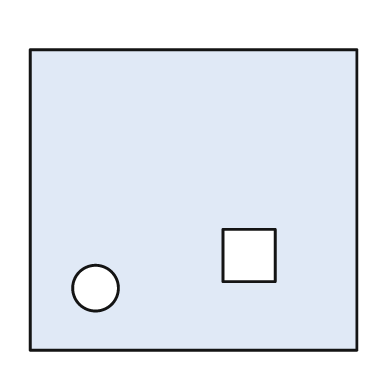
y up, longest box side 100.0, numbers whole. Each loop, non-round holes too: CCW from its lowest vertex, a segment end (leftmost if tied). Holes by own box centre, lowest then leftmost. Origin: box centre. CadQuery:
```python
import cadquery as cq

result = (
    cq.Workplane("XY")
    .moveTo(-50.0, -46.0)
    .lineTo(50.0, -46.0)
    .lineTo(50.0, 46.0)
    .lineTo(-50.0, 46.0)
    .close()
    .moveTo(-30.0, -27.0)
    .circle(7.0)
    .moveTo(9.0, -25.0)
    .lineTo(25.0, -25.0)
    .lineTo(25.0, -9.0)
    .lineTo(9.0, -9.0)
    .close()
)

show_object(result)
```